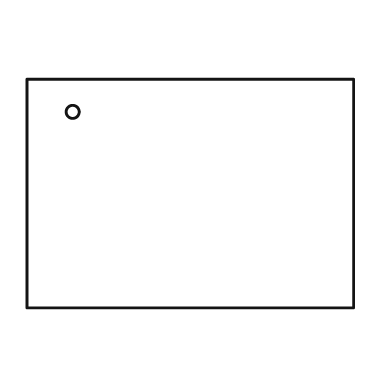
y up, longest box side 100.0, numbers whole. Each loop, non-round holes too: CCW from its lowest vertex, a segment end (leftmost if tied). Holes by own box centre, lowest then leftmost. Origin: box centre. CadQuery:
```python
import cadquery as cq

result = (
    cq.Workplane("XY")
    .moveTo(-50.0, -35.0)
    .lineTo(50.0, -35.0)
    .lineTo(50.0, 35.0)
    .lineTo(-50.0, 35.0)
    .close()
    .moveTo(-36.0, 25.0)
    .circle(2.0)
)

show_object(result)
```